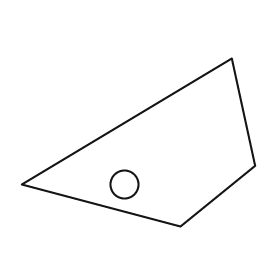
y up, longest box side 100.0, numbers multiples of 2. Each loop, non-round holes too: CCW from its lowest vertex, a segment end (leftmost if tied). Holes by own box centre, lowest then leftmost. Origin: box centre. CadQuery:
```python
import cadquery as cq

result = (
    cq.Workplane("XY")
    .moveTo(18.0, -36.0)
    .lineTo(50.0, -10.0)
    .lineTo(40.0, 36.0)
    .lineTo(-50.0, -18.0)
    .close()
    .moveTo(-6.0, -18.0)
    .circle(6.0)
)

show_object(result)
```